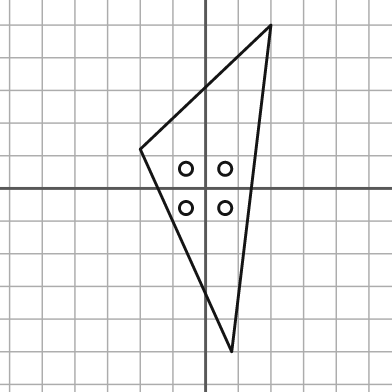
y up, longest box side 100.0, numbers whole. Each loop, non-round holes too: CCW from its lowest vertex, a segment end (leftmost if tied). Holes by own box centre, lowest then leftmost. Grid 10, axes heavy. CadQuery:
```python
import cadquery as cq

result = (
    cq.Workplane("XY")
    .moveTo(8.0, -50.0)
    .lineTo(20.0, 50.0)
    .lineTo(-20.0, 12.0)
    .close()
    .moveTo(-6.0, -6.0)
    .circle(2.0)
    .moveTo(6.0, -6.0)
    .circle(2.0)
    .moveTo(-6.0, 6.0)
    .circle(2.0)
    .moveTo(6.0, 6.0)
    .circle(2.0)
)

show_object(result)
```